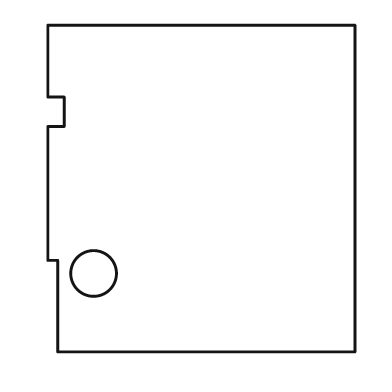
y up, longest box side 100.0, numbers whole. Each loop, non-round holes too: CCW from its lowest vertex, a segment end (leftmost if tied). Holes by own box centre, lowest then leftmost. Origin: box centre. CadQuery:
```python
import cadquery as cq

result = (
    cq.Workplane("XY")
    .moveTo(-44.0, -50.0)
    .lineTo(47.0, -50.0)
    .lineTo(47.0, 50.0)
    .lineTo(-47.0, 50.0)
    .lineTo(-47.0, 28.0)
    .lineTo(-42.0, 28.0)
    .lineTo(-42.0, 19.0)
    .lineTo(-47.0, 19.0)
    .lineTo(-47.0, -22.0)
    .lineTo(-44.0, -22.0)
    .close()
    .moveTo(-33.0, -26.0)
    .circle(7.0)
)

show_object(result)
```